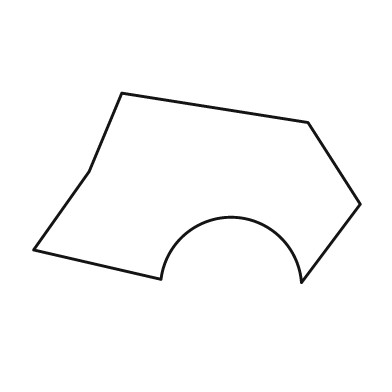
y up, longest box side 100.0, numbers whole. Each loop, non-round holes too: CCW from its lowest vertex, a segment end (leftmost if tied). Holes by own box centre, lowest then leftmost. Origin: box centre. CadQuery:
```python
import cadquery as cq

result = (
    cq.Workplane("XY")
    .moveTo(32.0, -29.0)
    .lineTo(50.0, -5.0)
    .lineTo(34.0, 20.0)
    .lineTo(-23.0, 29.0)
    .lineTo(-33.0, 5.0)
    .lineTo(-50.0, -19.0)
    .lineTo(-11.0, -28.0)
    .threePointArc((11.0, -9.0), (32.0, -29.0))
    .close()
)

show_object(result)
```